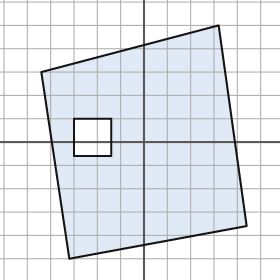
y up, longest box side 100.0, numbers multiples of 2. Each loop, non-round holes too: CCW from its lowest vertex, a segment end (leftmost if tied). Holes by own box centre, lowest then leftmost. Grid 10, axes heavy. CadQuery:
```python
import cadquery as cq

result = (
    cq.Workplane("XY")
    .moveTo(-32.0, -50.0)
    .lineTo(44.0, -36.0)
    .lineTo(32.0, 50.0)
    .lineTo(-44.0, 30.0)
    .close()
    .moveTo(-30.0, -6.0)
    .lineTo(-14.0, -6.0)
    .lineTo(-14.0, 10.0)
    .lineTo(-30.0, 10.0)
    .close()
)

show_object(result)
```